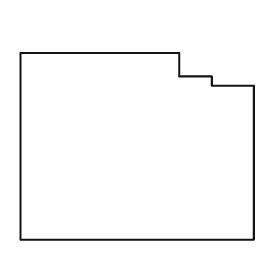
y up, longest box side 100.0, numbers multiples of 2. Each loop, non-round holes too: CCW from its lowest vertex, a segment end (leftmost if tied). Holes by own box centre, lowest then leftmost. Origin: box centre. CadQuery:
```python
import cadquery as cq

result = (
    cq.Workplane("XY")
    .moveTo(-50.0, -40.0)
    .lineTo(50.0, -40.0)
    .lineTo(50.0, 26.0)
    .lineTo(32.0, 26.0)
    .lineTo(32.0, 30.0)
    .lineTo(18.0, 30.0)
    .lineTo(18.0, 40.0)
    .lineTo(-50.0, 40.0)
    .close()
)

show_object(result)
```